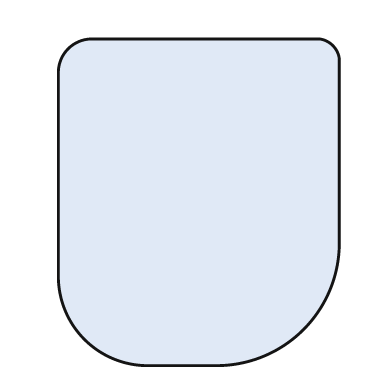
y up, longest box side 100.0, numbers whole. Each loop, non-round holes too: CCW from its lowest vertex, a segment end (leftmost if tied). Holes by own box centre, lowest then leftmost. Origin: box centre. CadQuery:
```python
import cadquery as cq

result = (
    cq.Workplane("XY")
    .moveTo(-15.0, -50.0)
    .lineTo(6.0, -50.0)
    .threePointArc((32.0, -39.0), (43.0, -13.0))
    .lineTo(43.0, 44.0)
    .threePointArc((41.0, 48.0), (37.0, 50.0))
    .lineTo(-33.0, 50.0)
    .threePointArc((-40.0, 47.0), (-43.0, 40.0))
    .lineTo(-43.0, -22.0)
    .threePointArc((-35.0, -42.0), (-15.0, -50.0))
    .close()
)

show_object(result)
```